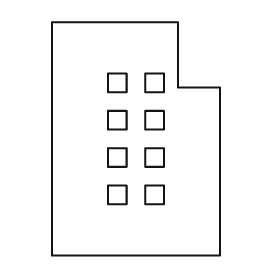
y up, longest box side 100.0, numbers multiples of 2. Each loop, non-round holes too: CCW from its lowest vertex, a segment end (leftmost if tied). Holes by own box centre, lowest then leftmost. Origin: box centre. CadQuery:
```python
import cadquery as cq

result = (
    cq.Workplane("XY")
    .moveTo(-36.0, -50.0)
    .lineTo(36.0, -50.0)
    .lineTo(36.0, 22.0)
    .lineTo(18.0, 22.0)
    .lineTo(18.0, 50.0)
    .lineTo(-36.0, 50.0)
    .close()
    .moveTo(-12.0, -28.0)
    .lineTo(-4.0, -28.0)
    .lineTo(-4.0, -20.0)
    .lineTo(-12.0, -20.0)
    .close()
    .moveTo(4.0, -28.0)
    .lineTo(12.0, -28.0)
    .lineTo(12.0, -20.0)
    .lineTo(4.0, -20.0)
    .close()
    .moveTo(-12.0, -12.0)
    .lineTo(-4.0, -12.0)
    .lineTo(-4.0, -4.0)
    .lineTo(-12.0, -4.0)
    .close()
    .moveTo(4.0, -12.0)
    .lineTo(12.0, -12.0)
    .lineTo(12.0, -4.0)
    .lineTo(4.0, -4.0)
    .close()
    .moveTo(-12.0, 4.0)
    .lineTo(-4.0, 4.0)
    .lineTo(-4.0, 12.0)
    .lineTo(-12.0, 12.0)
    .close()
    .moveTo(4.0, 4.0)
    .lineTo(12.0, 4.0)
    .lineTo(12.0, 12.0)
    .lineTo(4.0, 12.0)
    .close()
    .moveTo(-12.0, 20.0)
    .lineTo(-4.0, 20.0)
    .lineTo(-4.0, 28.0)
    .lineTo(-12.0, 28.0)
    .close()
    .moveTo(4.0, 20.0)
    .lineTo(12.0, 20.0)
    .lineTo(12.0, 28.0)
    .lineTo(4.0, 28.0)
    .close()
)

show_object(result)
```